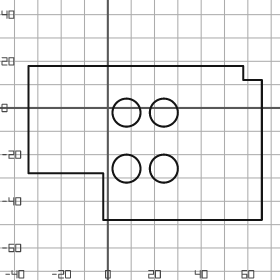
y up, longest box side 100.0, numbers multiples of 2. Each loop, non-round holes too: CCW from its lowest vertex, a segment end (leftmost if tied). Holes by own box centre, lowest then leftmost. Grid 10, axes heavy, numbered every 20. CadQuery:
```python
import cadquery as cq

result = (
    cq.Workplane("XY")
    .moveTo(-2.0, -48.0)
    .lineTo(66.0, -48.0)
    .lineTo(66.0, 12.0)
    .lineTo(58.0, 12.0)
    .lineTo(58.0, 18.0)
    .lineTo(-34.0, 18.0)
    .lineTo(-34.0, -28.0)
    .lineTo(-2.0, -28.0)
    .close()
    .moveTo(8.0, -26.0)
    .circle(6.0)
    .moveTo(24.0, -26.0)
    .circle(6.0)
    .moveTo(8.0, -2.0)
    .circle(6.0)
    .moveTo(24.0, -2.0)
    .circle(6.0)
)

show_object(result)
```